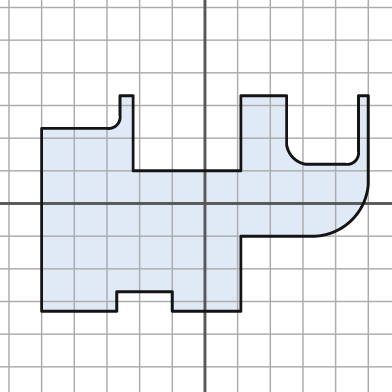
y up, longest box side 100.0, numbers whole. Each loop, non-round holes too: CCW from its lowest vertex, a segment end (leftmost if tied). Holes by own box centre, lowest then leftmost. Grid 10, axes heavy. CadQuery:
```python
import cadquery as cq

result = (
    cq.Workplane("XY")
    .moveTo(-50.0, -33.0)
    .lineTo(-27.0, -33.0)
    .lineTo(-27.0, -27.0)
    .lineTo(-10.0, -27.0)
    .lineTo(-10.0, -33.0)
    .lineTo(11.0, -33.0)
    .lineTo(11.0, -10.0)
    .lineTo(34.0, -10.0)
    .threePointArc((45.0, -5.0), (50.0, 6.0))
    .lineTo(50.0, 33.0)
    .lineTo(47.0, 33.0)
    .lineTo(47.0, 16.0)
    .threePointArc((46.0, 13.0), (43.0, 12.0))
    .lineTo(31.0, 12.0)
    .threePointArc((27.0, 14.0), (25.0, 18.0))
    .lineTo(25.0, 33.0)
    .lineTo(11.0, 33.0)
    .lineTo(11.0, 10.0)
    .lineTo(-22.0, 10.0)
    .lineTo(-22.0, 33.0)
    .lineTo(-26.0, 33.0)
    .lineTo(-26.0, 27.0)
    .threePointArc((-27.0, 24.0), (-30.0, 23.0))
    .lineTo(-50.0, 23.0)
    .close()
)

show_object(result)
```